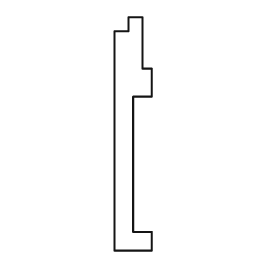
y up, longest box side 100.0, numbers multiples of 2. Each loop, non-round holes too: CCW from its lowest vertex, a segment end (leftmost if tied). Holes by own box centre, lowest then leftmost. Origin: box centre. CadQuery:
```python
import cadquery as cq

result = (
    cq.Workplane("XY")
    .moveTo(-8.0, -50.0)
    .lineTo(8.0, -50.0)
    .lineTo(8.0, -42.0)
    .lineTo(0.0, -42.0)
    .lineTo(0.0, 16.0)
    .lineTo(8.0, 16.0)
    .lineTo(8.0, 28.0)
    .lineTo(4.0, 28.0)
    .lineTo(4.0, 50.0)
    .lineTo(-2.0, 50.0)
    .lineTo(-2.0, 44.0)
    .lineTo(-8.0, 44.0)
    .close()
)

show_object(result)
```